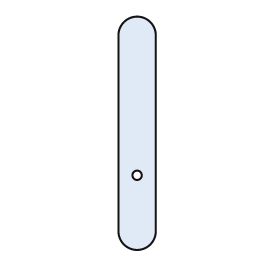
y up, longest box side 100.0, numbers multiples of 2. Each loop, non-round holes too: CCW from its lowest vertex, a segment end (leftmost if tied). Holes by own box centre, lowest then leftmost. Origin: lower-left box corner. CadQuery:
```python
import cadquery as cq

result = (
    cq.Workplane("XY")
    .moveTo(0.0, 8.0)
    .threePointArc((8.0, 0.0), (16.0, 8.0))
    .lineTo(16.0, 92.0)
    .threePointArc((8.0, 100.0), (0.0, 92.0))
    .close()
    .moveTo(8.0, 32.0)
    .circle(2.0)
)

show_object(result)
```